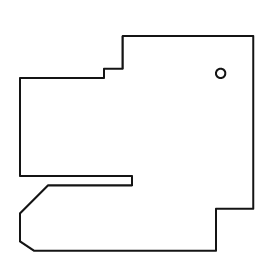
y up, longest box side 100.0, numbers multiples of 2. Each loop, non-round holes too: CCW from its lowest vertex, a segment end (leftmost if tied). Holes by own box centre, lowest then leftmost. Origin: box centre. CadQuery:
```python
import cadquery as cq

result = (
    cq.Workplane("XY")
    .moveTo(-44.0, -46.0)
    .lineTo(34.0, -46.0)
    .lineTo(34.0, -28.0)
    .lineTo(50.0, -28.0)
    .lineTo(50.0, 46.0)
    .lineTo(-6.0, 46.0)
    .lineTo(-6.0, 32.0)
    .lineTo(-14.0, 32.0)
    .lineTo(-14.0, 28.0)
    .lineTo(-50.0, 28.0)
    .lineTo(-50.0, -14.0)
    .lineTo(-2.0, -14.0)
    .lineTo(-2.0, -18.0)
    .lineTo(-38.0, -18.0)
    .lineTo(-50.0, -30.0)
    .lineTo(-50.0, -42.0)
    .close()
    .moveTo(36.0, 30.0)
    .circle(2.0)
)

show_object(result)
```